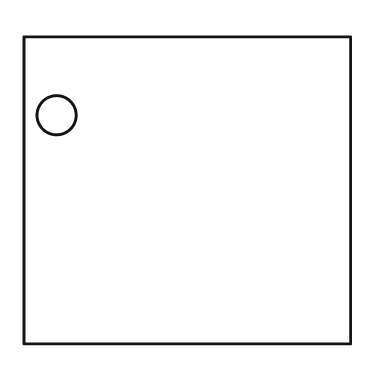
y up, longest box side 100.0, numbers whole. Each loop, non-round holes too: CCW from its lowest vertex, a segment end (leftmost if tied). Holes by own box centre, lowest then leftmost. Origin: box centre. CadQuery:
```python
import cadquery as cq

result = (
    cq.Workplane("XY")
    .moveTo(-50.0, -47.0)
    .lineTo(50.0, -47.0)
    .lineTo(50.0, 47.0)
    .lineTo(-50.0, 47.0)
    .close()
    .moveTo(-40.0, 23.0)
    .circle(6.0)
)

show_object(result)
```